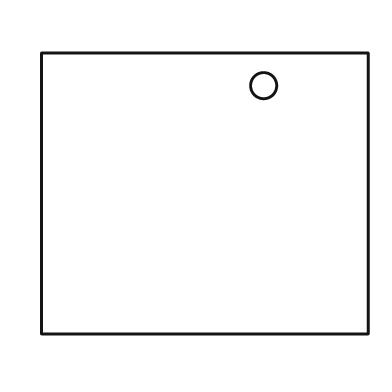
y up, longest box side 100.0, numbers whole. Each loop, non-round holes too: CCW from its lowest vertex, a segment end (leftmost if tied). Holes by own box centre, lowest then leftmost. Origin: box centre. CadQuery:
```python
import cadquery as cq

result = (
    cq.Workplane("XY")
    .moveTo(-50.0, -43.0)
    .lineTo(50.0, -43.0)
    .lineTo(50.0, 43.0)
    .lineTo(-50.0, 43.0)
    .close()
    .moveTo(18.0, 33.0)
    .circle(4.0)
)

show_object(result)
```